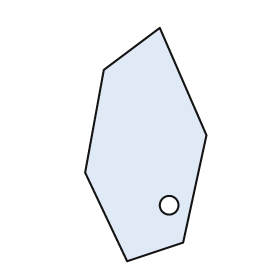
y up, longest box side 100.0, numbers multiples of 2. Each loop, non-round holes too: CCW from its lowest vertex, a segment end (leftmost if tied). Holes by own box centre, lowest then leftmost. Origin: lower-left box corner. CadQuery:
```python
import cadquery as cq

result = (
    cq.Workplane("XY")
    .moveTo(18.0, 0.0)
    .lineTo(42.0, 8.0)
    .lineTo(52.0, 54.0)
    .lineTo(32.0, 100.0)
    .lineTo(8.0, 82.0)
    .lineTo(0.0, 38.0)
    .close()
    .moveTo(36.0, 24.0)
    .circle(4.0)
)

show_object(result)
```